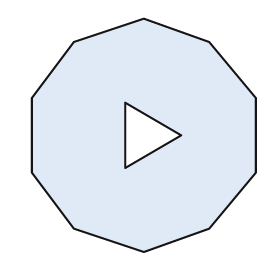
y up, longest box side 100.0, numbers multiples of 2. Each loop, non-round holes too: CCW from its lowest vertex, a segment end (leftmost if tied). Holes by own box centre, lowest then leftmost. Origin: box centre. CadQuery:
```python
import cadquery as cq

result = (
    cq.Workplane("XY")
    .moveTo(0.0, -50.0)
    .lineTo(28.0, -40.0)
    .lineTo(48.0, -16.0)
    .lineTo(48.0, 16.0)
    .lineTo(28.0, 40.0)
    .lineTo(0.0, 50.0)
    .lineTo(-30.0, 40.0)
    .lineTo(-48.0, 16.0)
    .lineTo(-48.0, -16.0)
    .lineTo(-30.0, -40.0)
    .close()
    .moveTo(-8.0, -14.0)
    .lineTo(16.0, 0.0)
    .lineTo(-8.0, 14.0)
    .close()
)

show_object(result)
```